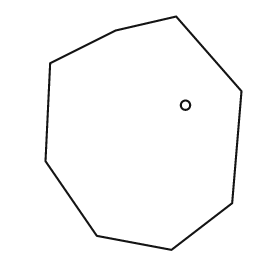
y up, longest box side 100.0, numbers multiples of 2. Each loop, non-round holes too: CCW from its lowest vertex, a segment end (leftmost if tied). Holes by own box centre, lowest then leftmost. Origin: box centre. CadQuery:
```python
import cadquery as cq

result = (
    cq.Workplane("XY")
    .moveTo(12.0, -50.0)
    .lineTo(38.0, -30.0)
    .lineTo(42.0, 18.0)
    .lineTo(14.0, 50.0)
    .lineTo(-12.0, 44.0)
    .lineTo(-40.0, 30.0)
    .lineTo(-42.0, -12.0)
    .lineTo(-20.0, -44.0)
    .close()
    .moveTo(18.0, 12.0)
    .circle(2.0)
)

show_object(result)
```